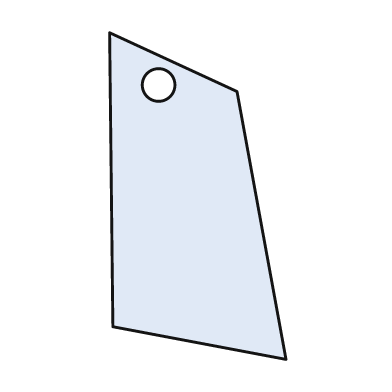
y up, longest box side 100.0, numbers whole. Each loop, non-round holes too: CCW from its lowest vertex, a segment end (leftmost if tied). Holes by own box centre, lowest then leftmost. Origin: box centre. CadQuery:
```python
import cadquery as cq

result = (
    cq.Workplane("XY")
    .moveTo(27.0, -50.0)
    .lineTo(12.0, 32.0)
    .lineTo(-27.0, 50.0)
    .lineTo(-26.0, -40.0)
    .close()
    .moveTo(-12.0, 34.0)
    .circle(5.0)
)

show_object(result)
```